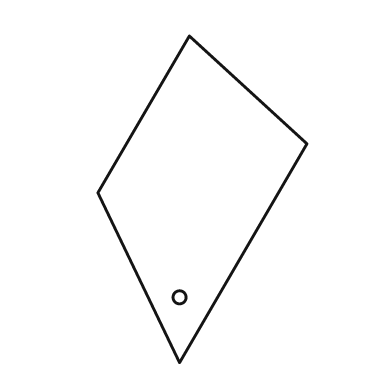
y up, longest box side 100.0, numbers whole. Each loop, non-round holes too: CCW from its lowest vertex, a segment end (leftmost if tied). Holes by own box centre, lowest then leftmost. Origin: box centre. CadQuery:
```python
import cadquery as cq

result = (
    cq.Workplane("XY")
    .moveTo(-7.0, -50.0)
    .lineTo(32.0, 17.0)
    .lineTo(-4.0, 50.0)
    .lineTo(-32.0, 2.0)
    .close()
    .moveTo(-7.0, -30.0)
    .circle(2.0)
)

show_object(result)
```